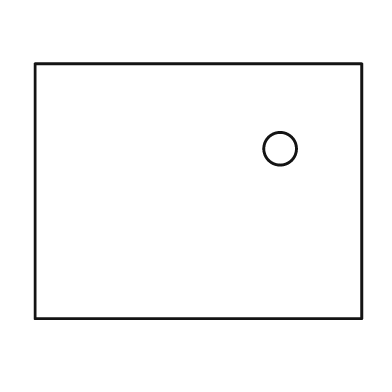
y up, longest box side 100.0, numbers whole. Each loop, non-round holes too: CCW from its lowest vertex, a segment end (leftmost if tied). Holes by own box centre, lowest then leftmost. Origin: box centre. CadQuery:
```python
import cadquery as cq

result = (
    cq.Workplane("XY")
    .moveTo(-50.0, -39.0)
    .lineTo(50.0, -39.0)
    .lineTo(50.0, 39.0)
    .lineTo(-50.0, 39.0)
    .close()
    .moveTo(25.0, 13.0)
    .circle(5.0)
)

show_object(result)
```